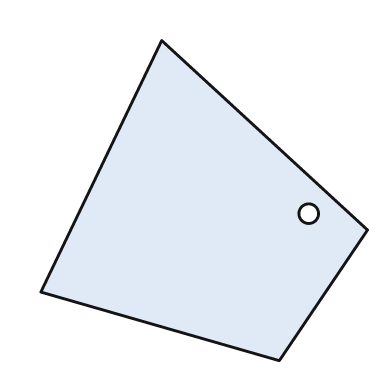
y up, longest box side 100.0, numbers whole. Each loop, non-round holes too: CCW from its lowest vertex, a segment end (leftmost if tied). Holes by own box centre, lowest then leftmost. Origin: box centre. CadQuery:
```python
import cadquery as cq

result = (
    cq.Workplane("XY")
    .moveTo(23.0, -49.0)
    .lineTo(50.0, -9.0)
    .lineTo(-13.0, 49.0)
    .lineTo(-50.0, -28.0)
    .close()
    .moveTo(32.0, -4.0)
    .circle(3.0)
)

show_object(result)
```